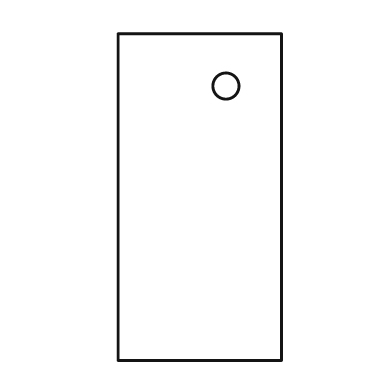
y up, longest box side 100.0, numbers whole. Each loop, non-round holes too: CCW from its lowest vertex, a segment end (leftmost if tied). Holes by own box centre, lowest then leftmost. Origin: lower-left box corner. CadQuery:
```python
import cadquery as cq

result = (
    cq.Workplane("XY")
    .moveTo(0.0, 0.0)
    .lineTo(50.0, 0.0)
    .lineTo(50.0, 100.0)
    .lineTo(0.0, 100.0)
    .close()
    .moveTo(33.0, 84.0)
    .circle(4.0)
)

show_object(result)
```